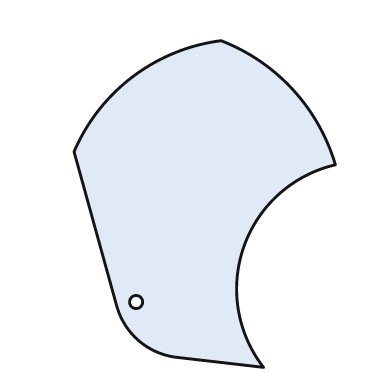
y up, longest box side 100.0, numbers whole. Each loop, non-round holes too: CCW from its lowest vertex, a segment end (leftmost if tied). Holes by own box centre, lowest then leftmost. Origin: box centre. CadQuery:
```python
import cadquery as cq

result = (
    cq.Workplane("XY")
    .moveTo(18.0, -50.0)
    .threePointArc((12.0, -13.0), (40.0, 12.0))
    .threePointArc((27.0, 35.0), (5.0, 50.0))
    .threePointArc((-22.0, 39.0), (-40.0, 16.0))
    .lineTo(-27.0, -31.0)
    .threePointArc((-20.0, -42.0), (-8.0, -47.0))
    .close()
    .moveTo(-21.0, -30.0)
    .circle(2.0)
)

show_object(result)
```